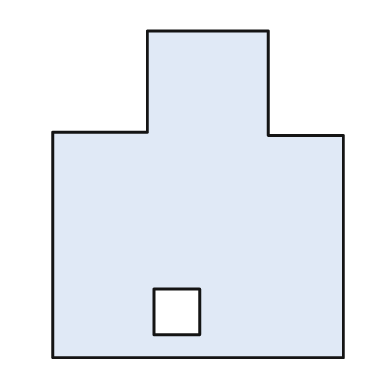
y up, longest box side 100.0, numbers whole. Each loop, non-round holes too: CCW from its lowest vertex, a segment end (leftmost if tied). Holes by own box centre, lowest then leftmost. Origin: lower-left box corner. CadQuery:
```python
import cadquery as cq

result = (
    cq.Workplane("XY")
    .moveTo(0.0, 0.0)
    .lineTo(89.0, 0.0)
    .lineTo(89.0, 68.0)
    .lineTo(66.0, 68.0)
    .lineTo(66.0, 100.0)
    .lineTo(29.0, 100.0)
    .lineTo(29.0, 69.0)
    .lineTo(0.0, 69.0)
    .close()
    .moveTo(31.0, 7.0)
    .lineTo(45.0, 7.0)
    .lineTo(45.0, 21.0)
    .lineTo(31.0, 21.0)
    .close()
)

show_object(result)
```